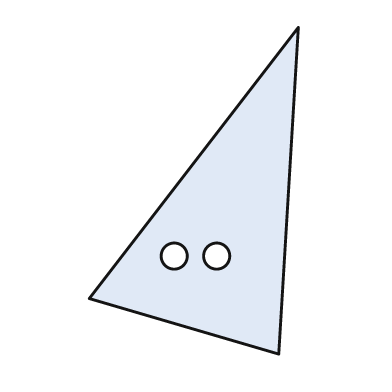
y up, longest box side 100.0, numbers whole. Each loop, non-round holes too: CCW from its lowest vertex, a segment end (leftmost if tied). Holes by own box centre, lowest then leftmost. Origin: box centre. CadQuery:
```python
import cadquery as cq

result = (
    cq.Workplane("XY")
    .moveTo(26.0, -50.0)
    .lineTo(32.0, 50.0)
    .lineTo(-32.0, -33.0)
    .close()
    .moveTo(-6.0, -20.0)
    .circle(4.0)
    .moveTo(7.0, -20.0)
    .circle(4.0)
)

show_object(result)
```